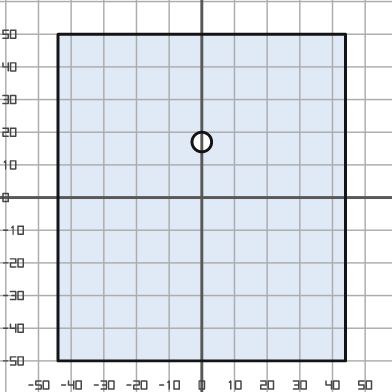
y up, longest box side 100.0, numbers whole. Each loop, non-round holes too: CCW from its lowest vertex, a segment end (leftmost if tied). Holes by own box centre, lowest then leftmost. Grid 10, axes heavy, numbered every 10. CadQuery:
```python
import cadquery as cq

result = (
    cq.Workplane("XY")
    .moveTo(-44.0, -50.0)
    .lineTo(44.0, -50.0)
    .lineTo(44.0, 50.0)
    .lineTo(-44.0, 50.0)
    .close()
    .moveTo(0.0, 17.0)
    .circle(3.0)
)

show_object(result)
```